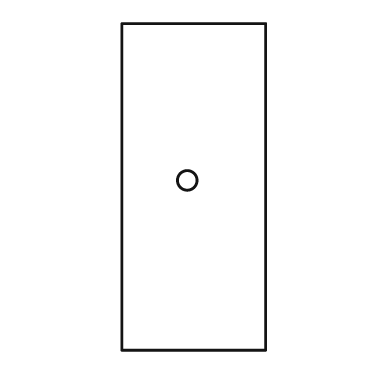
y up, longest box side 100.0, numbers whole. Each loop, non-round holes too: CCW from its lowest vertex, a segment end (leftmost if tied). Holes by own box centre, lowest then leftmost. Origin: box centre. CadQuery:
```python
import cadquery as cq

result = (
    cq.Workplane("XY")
    .moveTo(-22.0, -50.0)
    .lineTo(22.0, -50.0)
    .lineTo(22.0, 50.0)
    .lineTo(-22.0, 50.0)
    .close()
    .moveTo(-2.0, 2.0)
    .circle(3.0)
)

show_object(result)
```